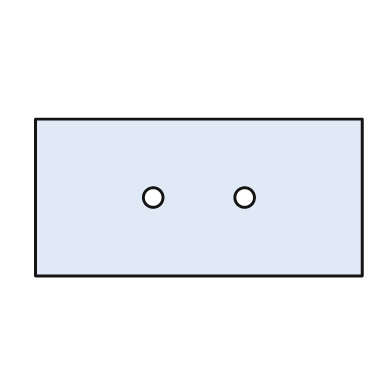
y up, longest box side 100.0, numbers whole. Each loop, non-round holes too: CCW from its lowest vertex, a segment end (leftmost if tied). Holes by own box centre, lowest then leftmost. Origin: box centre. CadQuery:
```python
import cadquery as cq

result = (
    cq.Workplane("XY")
    .moveTo(-50.0, -24.0)
    .lineTo(50.0, -24.0)
    .lineTo(50.0, 24.0)
    .lineTo(-50.0, 24.0)
    .close()
    .moveTo(-14.0, 0.0)
    .circle(3.0)
    .moveTo(14.0, 0.0)
    .circle(3.0)
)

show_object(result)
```